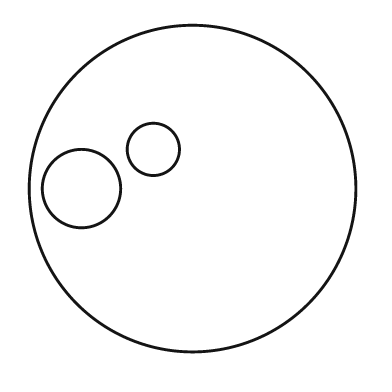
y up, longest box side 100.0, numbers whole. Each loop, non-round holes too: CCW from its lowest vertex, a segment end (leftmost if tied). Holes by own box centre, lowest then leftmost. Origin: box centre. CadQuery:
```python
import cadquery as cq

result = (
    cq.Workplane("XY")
    .moveTo(0.0, 0.0)
    .circle(50.0)
    .moveTo(-34.0, 0.0)
    .circle(12.0)
    .moveTo(-12.0, 12.0)
    .circle(8.0)
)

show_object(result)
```